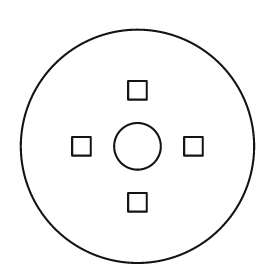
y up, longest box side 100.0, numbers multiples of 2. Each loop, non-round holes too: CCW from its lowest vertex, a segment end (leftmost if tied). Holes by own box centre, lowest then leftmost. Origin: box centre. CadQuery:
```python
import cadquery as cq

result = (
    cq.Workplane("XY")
    .moveTo(0.0, 0.0)
    .circle(50.0)
    .moveTo(-4.0, -28.0)
    .lineTo(4.0, -28.0)
    .lineTo(4.0, -20.0)
    .lineTo(-4.0, -20.0)
    .close()
    .moveTo(-28.0, -4.0)
    .lineTo(-20.0, -4.0)
    .lineTo(-20.0, 4.0)
    .lineTo(-28.0, 4.0)
    .close()
    .moveTo(0.0, 0.0)
    .circle(10.0)
    .moveTo(20.0, -4.0)
    .lineTo(28.0, -4.0)
    .lineTo(28.0, 4.0)
    .lineTo(20.0, 4.0)
    .close()
    .moveTo(-4.0, 20.0)
    .lineTo(4.0, 20.0)
    .lineTo(4.0, 28.0)
    .lineTo(-4.0, 28.0)
    .close()
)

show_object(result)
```